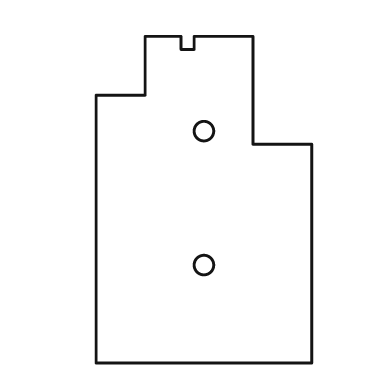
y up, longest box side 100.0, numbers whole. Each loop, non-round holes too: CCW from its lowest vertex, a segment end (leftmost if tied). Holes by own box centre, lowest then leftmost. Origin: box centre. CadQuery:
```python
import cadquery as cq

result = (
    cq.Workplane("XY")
    .moveTo(-33.0, -50.0)
    .lineTo(33.0, -50.0)
    .lineTo(33.0, 17.0)
    .lineTo(15.0, 17.0)
    .lineTo(15.0, 50.0)
    .lineTo(-3.0, 50.0)
    .lineTo(-3.0, 46.0)
    .lineTo(-7.0, 46.0)
    .lineTo(-7.0, 50.0)
    .lineTo(-18.0, 50.0)
    .lineTo(-18.0, 32.0)
    .lineTo(-33.0, 32.0)
    .close()
    .moveTo(0.0, -20.0)
    .circle(3.0)
    .moveTo(0.0, 21.0)
    .circle(3.0)
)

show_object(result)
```